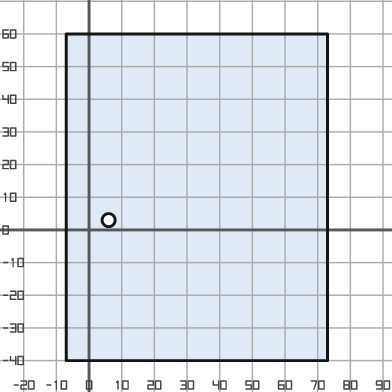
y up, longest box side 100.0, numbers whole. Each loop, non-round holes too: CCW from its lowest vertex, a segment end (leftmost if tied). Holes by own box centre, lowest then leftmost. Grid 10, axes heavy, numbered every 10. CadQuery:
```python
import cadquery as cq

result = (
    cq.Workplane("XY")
    .moveTo(-7.0, -40.0)
    .lineTo(73.0, -40.0)
    .lineTo(73.0, 60.0)
    .lineTo(-7.0, 60.0)
    .close()
    .moveTo(6.0, 3.0)
    .circle(2.0)
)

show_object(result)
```